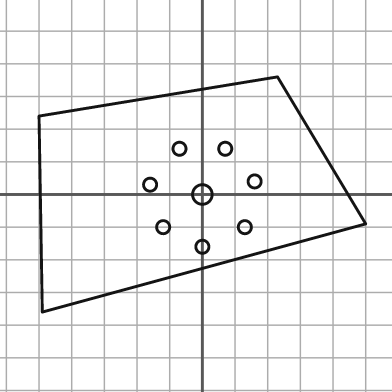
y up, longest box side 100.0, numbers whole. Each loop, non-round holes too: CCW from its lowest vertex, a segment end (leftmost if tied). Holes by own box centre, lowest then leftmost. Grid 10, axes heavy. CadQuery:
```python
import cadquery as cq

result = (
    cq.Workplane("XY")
    .moveTo(-49.0, -36.0)
    .lineTo(50.0, -9.0)
    .lineTo(23.0, 36.0)
    .lineTo(-50.0, 24.0)
    .close()
    .moveTo(0.0, -16.0)
    .circle(2.0)
    .moveTo(-12.0, -10.0)
    .circle(2.0)
    .moveTo(13.0, -10.0)
    .circle(2.0)
    .moveTo(0.0, 0.0)
    .circle(3.0)
    .moveTo(-16.0, 3.0)
    .circle(2.0)
    .moveTo(16.0, 4.0)
    .circle(2.0)
    .moveTo(-7.0, 14.0)
    .circle(2.0)
    .moveTo(7.0, 14.0)
    .circle(2.0)
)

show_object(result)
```